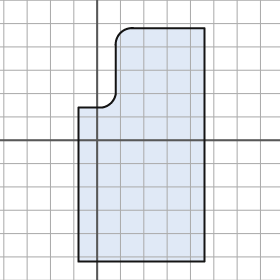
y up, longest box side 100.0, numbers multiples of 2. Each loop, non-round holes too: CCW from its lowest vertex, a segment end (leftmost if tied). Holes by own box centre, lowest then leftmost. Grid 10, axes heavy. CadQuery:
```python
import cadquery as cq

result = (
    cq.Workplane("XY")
    .moveTo(-8.0, -52.0)
    .lineTo(46.0, -52.0)
    .lineTo(46.0, 48.0)
    .lineTo(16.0, 48.0)
    .threePointArc((10.0, 46.0), (8.0, 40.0))
    .lineTo(8.0, 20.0)
    .threePointArc((6.0, 16.0), (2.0, 14.0))
    .lineTo(-8.0, 14.0)
    .close()
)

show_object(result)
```